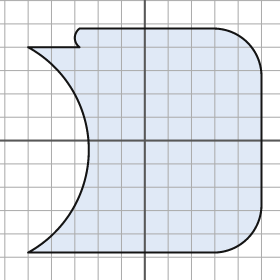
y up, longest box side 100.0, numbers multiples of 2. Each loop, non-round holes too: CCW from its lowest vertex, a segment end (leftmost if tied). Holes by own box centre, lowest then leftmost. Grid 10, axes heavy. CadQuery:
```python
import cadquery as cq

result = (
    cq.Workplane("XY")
    .moveTo(-50.0, -48.0)
    .lineTo(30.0, -48.0)
    .threePointArc((44.0, -42.0), (50.0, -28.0))
    .lineTo(50.0, 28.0)
    .threePointArc((44.0, 42.0), (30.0, 48.0))
    .lineTo(-28.0, 48.0)
    .threePointArc((-30.0, 44.0), (-28.0, 40.0))
    .lineTo(-50.0, 40.0)
    .threePointArc((-24.0, -4.0), (-50.0, -48.0))
    .close()
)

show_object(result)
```